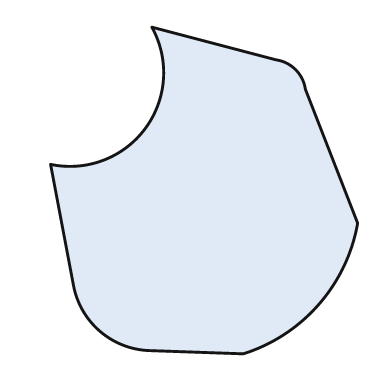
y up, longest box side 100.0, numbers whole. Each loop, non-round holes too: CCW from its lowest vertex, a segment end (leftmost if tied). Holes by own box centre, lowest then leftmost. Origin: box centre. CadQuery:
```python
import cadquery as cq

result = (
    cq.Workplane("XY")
    .moveTo(12.0, -50.0)
    .threePointArc((35.0, -35.0), (47.0, -10.0))
    .lineTo(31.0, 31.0)
    .threePointArc((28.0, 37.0), (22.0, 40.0))
    .lineTo(-16.0, 50.0)
    .threePointArc((-18.0, 19.0), (-47.0, 8.0))
    .lineTo(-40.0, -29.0)
    .threePointArc((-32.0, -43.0), (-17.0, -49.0))
    .close()
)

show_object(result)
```